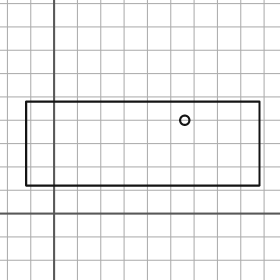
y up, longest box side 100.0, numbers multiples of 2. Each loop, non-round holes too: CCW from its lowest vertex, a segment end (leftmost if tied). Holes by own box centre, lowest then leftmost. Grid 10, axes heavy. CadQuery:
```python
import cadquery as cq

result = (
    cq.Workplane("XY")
    .moveTo(-12.0, 12.0)
    .lineTo(88.0, 12.0)
    .lineTo(88.0, 48.0)
    .lineTo(-12.0, 48.0)
    .close()
    .moveTo(56.0, 40.0)
    .circle(2.0)
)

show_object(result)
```